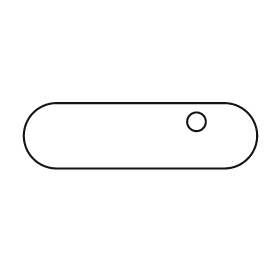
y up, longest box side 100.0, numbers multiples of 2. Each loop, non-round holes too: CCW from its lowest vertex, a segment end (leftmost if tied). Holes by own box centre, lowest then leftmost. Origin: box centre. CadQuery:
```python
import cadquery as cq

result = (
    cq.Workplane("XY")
    .moveTo(-36.0, -14.0)
    .lineTo(36.0, -14.0)
    .threePointArc((50.0, 0.0), (36.0, 14.0))
    .lineTo(-36.0, 14.0)
    .threePointArc((-50.0, 0.0), (-36.0, -14.0))
    .close()
    .moveTo(24.0, 6.0)
    .circle(4.0)
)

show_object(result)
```